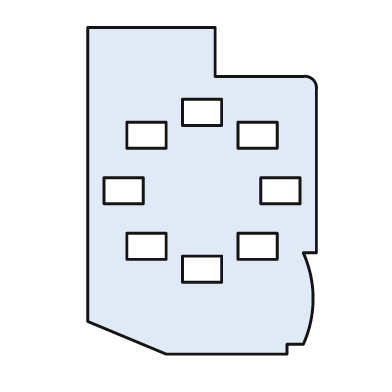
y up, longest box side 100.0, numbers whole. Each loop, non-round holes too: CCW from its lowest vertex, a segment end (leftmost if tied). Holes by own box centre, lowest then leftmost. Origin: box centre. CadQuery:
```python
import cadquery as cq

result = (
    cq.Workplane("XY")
    .moveTo(-11.0, -50.0)
    .lineTo(26.0, -50.0)
    .lineTo(26.0, -47.0)
    .lineTo(31.0, -47.0)
    .threePointArc((34.0, -33.0), (31.0, -19.0))
    .lineTo(35.0, -19.0)
    .lineTo(35.0, 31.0)
    .threePointArc((34.0, 34.0), (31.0, 35.0))
    .lineTo(4.0, 35.0)
    .lineTo(4.0, 50.0)
    .lineTo(-35.0, 50.0)
    .lineTo(-35.0, -40.0)
    .close()
    .moveTo(-6.0, -28.0)
    .lineTo(6.0, -28.0)
    .lineTo(6.0, -20.0)
    .lineTo(-6.0, -20.0)
    .close()
    .moveTo(-23.0, -21.0)
    .lineTo(-11.0, -21.0)
    .lineTo(-11.0, -13.0)
    .lineTo(-23.0, -13.0)
    .close()
    .moveTo(11.0, -21.0)
    .lineTo(23.0, -21.0)
    .lineTo(23.0, -13.0)
    .lineTo(11.0, -13.0)
    .close()
    .moveTo(-30.0, -4.0)
    .lineTo(-18.0, -4.0)
    .lineTo(-18.0, 4.0)
    .lineTo(-30.0, 4.0)
    .close()
    .moveTo(18.0, -4.0)
    .lineTo(30.0, -4.0)
    .lineTo(30.0, 4.0)
    .lineTo(18.0, 4.0)
    .close()
    .moveTo(-23.0, 13.0)
    .lineTo(-11.0, 13.0)
    .lineTo(-11.0, 21.0)
    .lineTo(-23.0, 21.0)
    .close()
    .moveTo(11.0, 13.0)
    .lineTo(23.0, 13.0)
    .lineTo(23.0, 21.0)
    .lineTo(11.0, 21.0)
    .close()
    .moveTo(-6.0, 20.0)
    .lineTo(6.0, 20.0)
    .lineTo(6.0, 28.0)
    .lineTo(-6.0, 28.0)
    .close()
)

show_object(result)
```